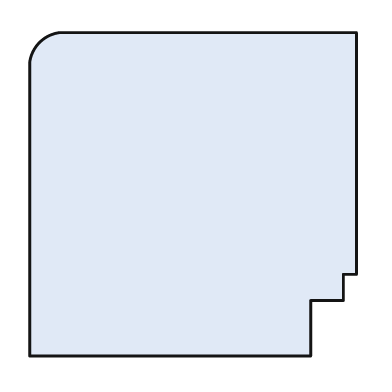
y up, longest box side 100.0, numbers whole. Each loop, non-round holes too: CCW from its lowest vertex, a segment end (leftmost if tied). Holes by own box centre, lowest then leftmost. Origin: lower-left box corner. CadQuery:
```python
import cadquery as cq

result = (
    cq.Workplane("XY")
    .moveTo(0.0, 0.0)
    .lineTo(86.0, 0.0)
    .lineTo(86.0, 17.0)
    .lineTo(96.0, 17.0)
    .lineTo(96.0, 25.0)
    .lineTo(100.0, 25.0)
    .lineTo(100.0, 99.0)
    .lineTo(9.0, 99.0)
    .threePointArc((3.0, 96.0), (0.0, 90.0))
    .close()
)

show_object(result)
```